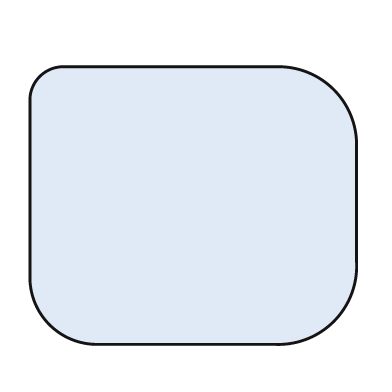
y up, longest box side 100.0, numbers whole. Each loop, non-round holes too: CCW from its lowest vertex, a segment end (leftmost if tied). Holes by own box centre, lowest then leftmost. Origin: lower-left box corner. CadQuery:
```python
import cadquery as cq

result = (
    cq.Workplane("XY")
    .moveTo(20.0, 0.0)
    .lineTo(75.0, 0.0)
    .threePointArc((93.0, 7.0), (100.0, 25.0))
    .lineTo(100.0, 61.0)
    .threePointArc((93.0, 78.0), (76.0, 85.0))
    .lineTo(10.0, 85.0)
    .threePointArc((3.0, 82.0), (0.0, 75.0))
    .lineTo(0.0, 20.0)
    .threePointArc((6.0, 6.0), (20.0, 0.0))
    .close()
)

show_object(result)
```